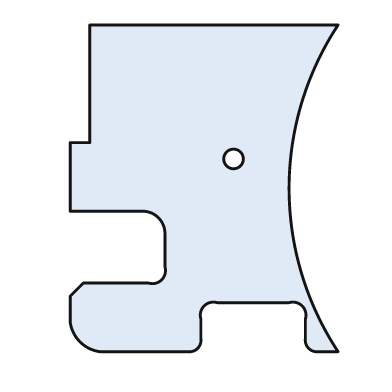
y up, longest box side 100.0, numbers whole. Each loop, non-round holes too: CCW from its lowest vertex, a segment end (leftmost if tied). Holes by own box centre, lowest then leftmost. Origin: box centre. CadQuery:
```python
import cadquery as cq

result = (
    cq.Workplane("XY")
    .moveTo(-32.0, -50.0)
    .lineTo(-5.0, -50.0)
    .threePointArc((-2.0, -49.0), (-1.0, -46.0))
    .lineTo(-1.0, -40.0)
    .threePointArc((0.0, -36.0), (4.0, -35.0))
    .lineTo(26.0, -35.0)
    .threePointArc((30.0, -36.0), (31.0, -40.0))
    .lineTo(31.0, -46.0)
    .threePointArc((32.0, -49.0), (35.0, -50.0))
    .lineTo(41.0, -50.0)
    .threePointArc((26.0, 0.0), (41.0, 50.0))
    .lineTo(-35.0, 50.0)
    .lineTo(-35.0, 14.0)
    .lineTo(-41.0, 14.0)
    .lineTo(-41.0, -7.0)
    .lineTo(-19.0, -7.0)
    .threePointArc((-14.0, -9.0), (-12.0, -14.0))
    .lineTo(-12.0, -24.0)
    .threePointArc((-13.0, -28.0), (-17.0, -29.0))
    .lineTo(-37.0, -29.0)
    .lineTo(-41.0, -33.0)
    .lineTo(-41.0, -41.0)
    .threePointArc((-38.0, -47.0), (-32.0, -50.0))
    .close()
    .moveTo(9.0, 9.0)
    .circle(3.0)
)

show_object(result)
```